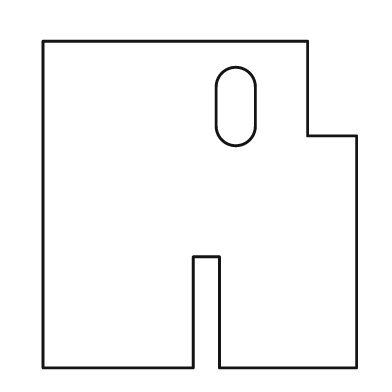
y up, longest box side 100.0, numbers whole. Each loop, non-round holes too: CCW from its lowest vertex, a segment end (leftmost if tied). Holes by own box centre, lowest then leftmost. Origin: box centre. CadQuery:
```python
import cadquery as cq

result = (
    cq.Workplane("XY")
    .moveTo(-48.0, -50.0)
    .lineTo(-2.0, -50.0)
    .lineTo(-2.0, -16.0)
    .lineTo(6.0, -16.0)
    .lineTo(6.0, -50.0)
    .lineTo(48.0, -50.0)
    .lineTo(48.0, 21.0)
    .lineTo(33.0, 21.0)
    .lineTo(33.0, 50.0)
    .lineTo(-48.0, 50.0)
    .close()
    .moveTo(5.0, 24.0)
    .threePointArc((11.0, 18.0), (17.0, 24.0))
    .lineTo(17.0, 36.0)
    .threePointArc((11.0, 42.0), (5.0, 36.0))
    .close()
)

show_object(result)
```